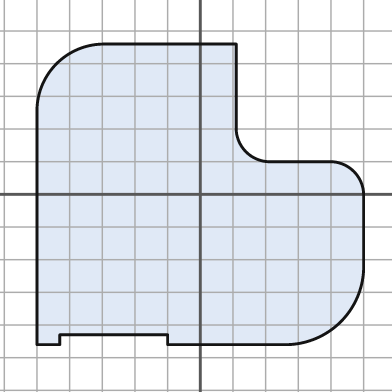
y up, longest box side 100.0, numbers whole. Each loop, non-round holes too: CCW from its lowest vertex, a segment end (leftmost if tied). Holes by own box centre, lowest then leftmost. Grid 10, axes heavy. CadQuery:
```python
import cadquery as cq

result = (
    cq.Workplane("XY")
    .moveTo(-50.0, -46.0)
    .lineTo(-43.0, -46.0)
    .lineTo(-43.0, -43.0)
    .lineTo(-10.0, -43.0)
    .lineTo(-10.0, -46.0)
    .lineTo(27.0, -46.0)
    .threePointArc((43.0, -39.0), (50.0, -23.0))
    .lineTo(50.0, 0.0)
    .threePointArc((47.0, 7.0), (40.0, 10.0))
    .lineTo(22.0, 10.0)
    .threePointArc((14.0, 13.0), (11.0, 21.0))
    .lineTo(11.0, 46.0)
    .lineTo(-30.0, 46.0)
    .threePointArc((-44.0, 40.0), (-50.0, 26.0))
    .close()
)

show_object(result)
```